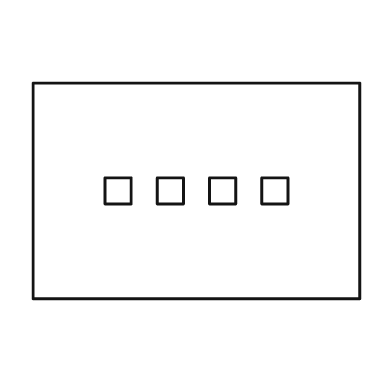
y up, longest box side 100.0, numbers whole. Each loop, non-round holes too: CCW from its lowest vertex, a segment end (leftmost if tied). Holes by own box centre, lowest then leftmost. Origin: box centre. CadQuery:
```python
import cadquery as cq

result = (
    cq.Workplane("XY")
    .moveTo(-50.0, -33.0)
    .lineTo(50.0, -33.0)
    .lineTo(50.0, 33.0)
    .lineTo(-50.0, 33.0)
    .close()
    .moveTo(-28.0, -4.0)
    .lineTo(-20.0, -4.0)
    .lineTo(-20.0, 4.0)
    .lineTo(-28.0, 4.0)
    .close()
    .moveTo(-12.0, -4.0)
    .lineTo(-4.0, -4.0)
    .lineTo(-4.0, 4.0)
    .lineTo(-12.0, 4.0)
    .close()
    .moveTo(4.0, -4.0)
    .lineTo(12.0, -4.0)
    .lineTo(12.0, 4.0)
    .lineTo(4.0, 4.0)
    .close()
    .moveTo(20.0, -4.0)
    .lineTo(28.0, -4.0)
    .lineTo(28.0, 4.0)
    .lineTo(20.0, 4.0)
    .close()
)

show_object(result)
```